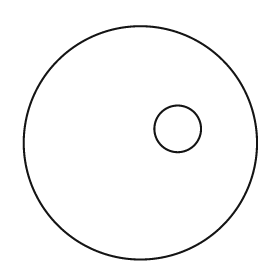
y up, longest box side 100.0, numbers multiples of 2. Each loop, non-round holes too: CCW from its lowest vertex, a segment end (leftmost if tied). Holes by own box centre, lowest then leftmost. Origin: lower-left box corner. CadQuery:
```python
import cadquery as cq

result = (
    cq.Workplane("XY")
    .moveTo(50.0, 50.0)
    .circle(50.0)
    .moveTo(66.0, 56.0)
    .circle(10.0)
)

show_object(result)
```